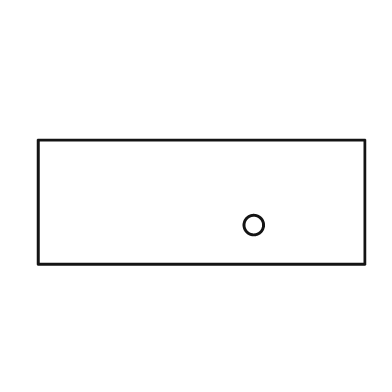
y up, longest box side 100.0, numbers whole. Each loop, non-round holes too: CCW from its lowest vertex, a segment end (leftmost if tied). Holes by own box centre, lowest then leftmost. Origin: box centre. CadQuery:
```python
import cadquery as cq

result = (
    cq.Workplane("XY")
    .moveTo(-50.0, -19.0)
    .lineTo(50.0, -19.0)
    .lineTo(50.0, 19.0)
    .lineTo(-50.0, 19.0)
    .close()
    .moveTo(16.0, -7.0)
    .circle(3.0)
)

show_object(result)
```